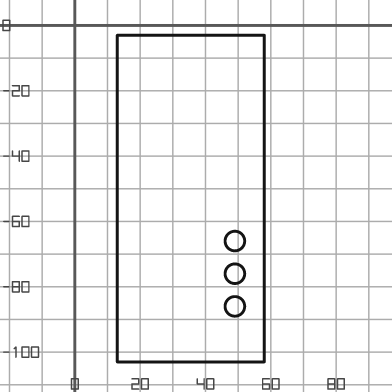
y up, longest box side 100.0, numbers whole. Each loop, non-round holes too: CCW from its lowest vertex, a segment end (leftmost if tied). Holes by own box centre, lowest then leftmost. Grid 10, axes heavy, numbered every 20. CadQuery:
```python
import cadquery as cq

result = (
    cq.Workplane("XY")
    .moveTo(13.0, -103.0)
    .lineTo(58.0, -103.0)
    .lineTo(58.0, -3.0)
    .lineTo(13.0, -3.0)
    .close()
    .moveTo(49.0, -86.0)
    .circle(3.0)
    .moveTo(49.0, -76.0)
    .circle(3.0)
    .moveTo(49.0, -66.0)
    .circle(3.0)
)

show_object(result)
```